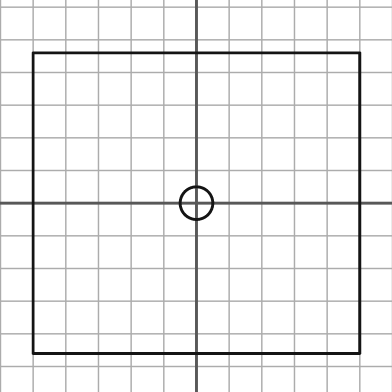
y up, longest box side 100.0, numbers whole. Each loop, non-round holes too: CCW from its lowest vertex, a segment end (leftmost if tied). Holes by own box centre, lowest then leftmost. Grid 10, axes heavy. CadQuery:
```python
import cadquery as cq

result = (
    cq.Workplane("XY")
    .moveTo(-50.0, -46.0)
    .lineTo(50.0, -46.0)
    .lineTo(50.0, 46.0)
    .lineTo(-50.0, 46.0)
    .close()
    .moveTo(0.0, 0.0)
    .circle(5.0)
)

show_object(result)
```